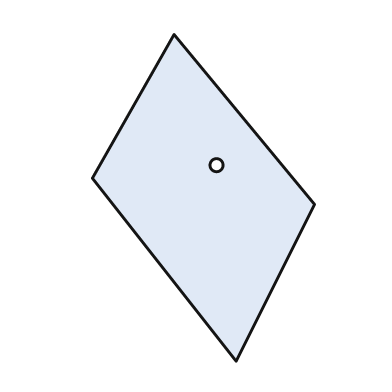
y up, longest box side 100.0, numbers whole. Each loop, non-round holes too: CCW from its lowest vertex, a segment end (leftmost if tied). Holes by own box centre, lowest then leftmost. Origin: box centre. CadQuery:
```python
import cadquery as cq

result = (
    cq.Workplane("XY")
    .moveTo(10.0, -50.0)
    .lineTo(34.0, -2.0)
    .lineTo(-9.0, 50.0)
    .lineTo(-34.0, 6.0)
    .close()
    .moveTo(4.0, 10.0)
    .circle(2.0)
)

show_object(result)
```